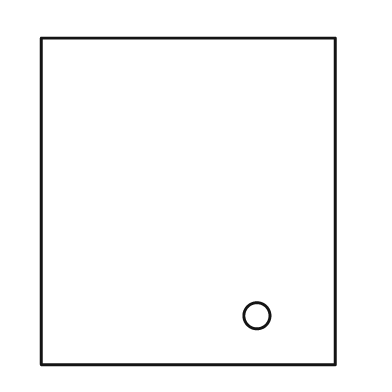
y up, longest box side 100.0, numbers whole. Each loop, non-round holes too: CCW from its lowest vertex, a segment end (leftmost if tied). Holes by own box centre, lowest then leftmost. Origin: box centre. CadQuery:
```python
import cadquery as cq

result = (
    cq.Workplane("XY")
    .moveTo(-45.0, -50.0)
    .lineTo(45.0, -50.0)
    .lineTo(45.0, 50.0)
    .lineTo(-45.0, 50.0)
    .close()
    .moveTo(21.0, -35.0)
    .circle(4.0)
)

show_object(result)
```